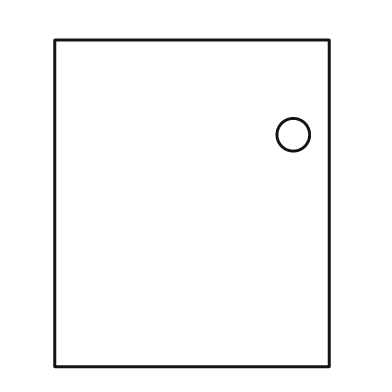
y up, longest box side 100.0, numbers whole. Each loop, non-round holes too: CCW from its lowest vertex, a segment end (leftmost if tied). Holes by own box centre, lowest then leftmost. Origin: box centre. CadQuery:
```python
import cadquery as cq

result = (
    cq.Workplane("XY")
    .moveTo(-42.0, -50.0)
    .lineTo(42.0, -50.0)
    .lineTo(42.0, 50.0)
    .lineTo(-42.0, 50.0)
    .close()
    .moveTo(31.0, 21.0)
    .circle(5.0)
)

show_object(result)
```